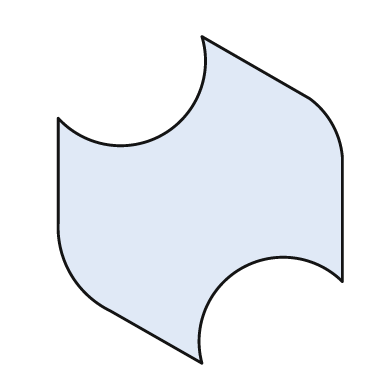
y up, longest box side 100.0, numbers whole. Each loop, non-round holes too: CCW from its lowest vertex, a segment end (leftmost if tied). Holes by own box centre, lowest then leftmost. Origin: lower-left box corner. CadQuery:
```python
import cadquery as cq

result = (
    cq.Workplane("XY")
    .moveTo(44.0, 0.0)
    .threePointArc((56.0, 29.0), (87.0, 25.0))
    .lineTo(87.0, 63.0)
    .threePointArc((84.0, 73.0), (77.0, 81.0))
    .lineTo(44.0, 100.0)
    .threePointArc((32.0, 70.0), (0.0, 75.0))
    .lineTo(0.0, 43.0)
    .threePointArc((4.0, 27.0), (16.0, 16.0))
    .close()
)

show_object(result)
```